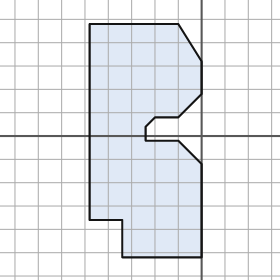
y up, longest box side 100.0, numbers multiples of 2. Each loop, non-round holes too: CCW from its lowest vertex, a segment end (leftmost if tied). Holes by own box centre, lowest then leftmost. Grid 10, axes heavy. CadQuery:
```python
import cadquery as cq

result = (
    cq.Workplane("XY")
    .moveTo(-34.0, -52.0)
    .lineTo(0.0, -52.0)
    .lineTo(0.0, -12.0)
    .lineTo(-10.0, -2.0)
    .lineTo(-24.0, -2.0)
    .lineTo(-24.0, 4.0)
    .lineTo(-20.0, 8.0)
    .lineTo(-10.0, 8.0)
    .lineTo(0.0, 18.0)
    .lineTo(0.0, 32.0)
    .lineTo(-10.0, 48.0)
    .lineTo(-48.0, 48.0)
    .lineTo(-48.0, -36.0)
    .lineTo(-34.0, -36.0)
    .close()
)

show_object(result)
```